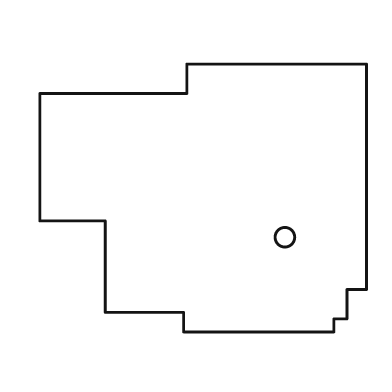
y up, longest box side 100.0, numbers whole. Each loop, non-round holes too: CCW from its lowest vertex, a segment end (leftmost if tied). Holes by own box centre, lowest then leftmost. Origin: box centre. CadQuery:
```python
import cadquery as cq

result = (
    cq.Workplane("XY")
    .moveTo(-6.0, -41.0)
    .lineTo(40.0, -41.0)
    .lineTo(40.0, -37.0)
    .lineTo(44.0, -37.0)
    .lineTo(44.0, -28.0)
    .lineTo(50.0, -28.0)
    .lineTo(50.0, 41.0)
    .lineTo(-5.0, 41.0)
    .lineTo(-5.0, 32.0)
    .lineTo(-50.0, 32.0)
    .lineTo(-50.0, -7.0)
    .lineTo(-30.0, -7.0)
    .lineTo(-30.0, -35.0)
    .lineTo(-6.0, -35.0)
    .close()
    .moveTo(25.0, -12.0)
    .circle(3.0)
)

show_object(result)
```